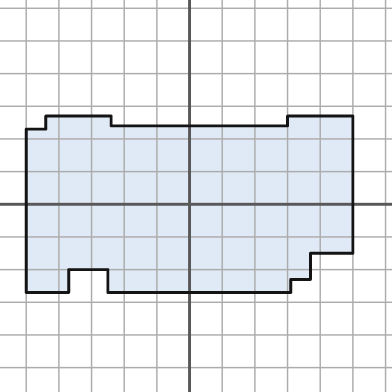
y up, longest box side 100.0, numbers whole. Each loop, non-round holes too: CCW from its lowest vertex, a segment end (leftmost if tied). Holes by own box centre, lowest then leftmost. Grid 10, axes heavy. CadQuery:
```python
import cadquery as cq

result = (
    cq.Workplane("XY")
    .moveTo(-50.0, -27.0)
    .lineTo(-37.0, -27.0)
    .lineTo(-37.0, -20.0)
    .lineTo(-25.0, -20.0)
    .lineTo(-25.0, -27.0)
    .lineTo(31.0, -27.0)
    .lineTo(31.0, -23.0)
    .lineTo(37.0, -23.0)
    .lineTo(37.0, -15.0)
    .lineTo(50.0, -15.0)
    .lineTo(50.0, 27.0)
    .lineTo(30.0, 27.0)
    .lineTo(30.0, 24.0)
    .lineTo(-24.0, 24.0)
    .lineTo(-24.0, 27.0)
    .lineTo(-44.0, 27.0)
    .lineTo(-44.0, 23.0)
    .lineTo(-50.0, 23.0)
    .close()
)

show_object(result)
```